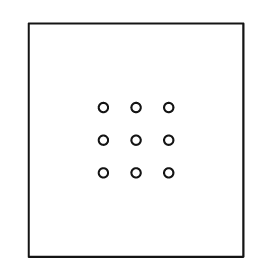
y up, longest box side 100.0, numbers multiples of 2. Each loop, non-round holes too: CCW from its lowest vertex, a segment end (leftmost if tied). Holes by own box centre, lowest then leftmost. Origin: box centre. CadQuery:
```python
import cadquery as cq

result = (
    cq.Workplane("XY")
    .moveTo(-46.0, -50.0)
    .lineTo(46.0, -50.0)
    .lineTo(46.0, 50.0)
    .lineTo(-46.0, 50.0)
    .close()
    .moveTo(-14.0, -14.0)
    .circle(2.0)
    .moveTo(0.0, -14.0)
    .circle(2.0)
    .moveTo(14.0, -14.0)
    .circle(2.0)
    .moveTo(-14.0, 0.0)
    .circle(2.0)
    .moveTo(0.0, 0.0)
    .circle(2.0)
    .moveTo(14.0, 0.0)
    .circle(2.0)
    .moveTo(-14.0, 14.0)
    .circle(2.0)
    .moveTo(0.0, 14.0)
    .circle(2.0)
    .moveTo(14.0, 14.0)
    .circle(2.0)
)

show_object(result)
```